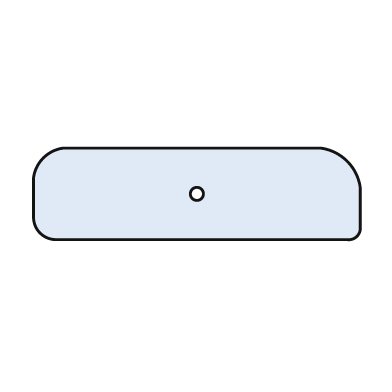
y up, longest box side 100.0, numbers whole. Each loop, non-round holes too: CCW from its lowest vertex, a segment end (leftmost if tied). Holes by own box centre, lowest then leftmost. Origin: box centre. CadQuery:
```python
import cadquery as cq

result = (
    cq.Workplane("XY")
    .moveTo(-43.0, -14.0)
    .lineTo(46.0, -14.0)
    .threePointArc((49.0, -13.0), (50.0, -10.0))
    .lineTo(50.0, 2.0)
    .threePointArc((46.0, 10.0), (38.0, 14.0))
    .lineTo(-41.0, 14.0)
    .threePointArc((-47.0, 11.0), (-50.0, 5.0))
    .lineTo(-50.0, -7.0)
    .threePointArc((-48.0, -12.0), (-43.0, -14.0))
    .close()
    .moveTo(0.0, 0.0)
    .circle(2.0)
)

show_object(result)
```